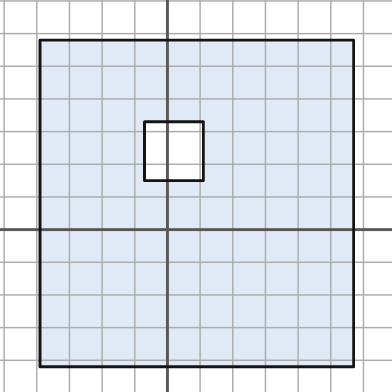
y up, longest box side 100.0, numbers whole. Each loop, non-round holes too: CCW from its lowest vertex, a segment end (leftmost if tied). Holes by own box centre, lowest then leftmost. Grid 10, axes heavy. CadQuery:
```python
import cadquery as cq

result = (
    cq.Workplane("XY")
    .moveTo(-39.0, -42.0)
    .lineTo(57.0, -42.0)
    .lineTo(57.0, 58.0)
    .lineTo(-39.0, 58.0)
    .close()
    .moveTo(-7.0, 15.0)
    .lineTo(11.0, 15.0)
    .lineTo(11.0, 33.0)
    .lineTo(-7.0, 33.0)
    .close()
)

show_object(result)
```